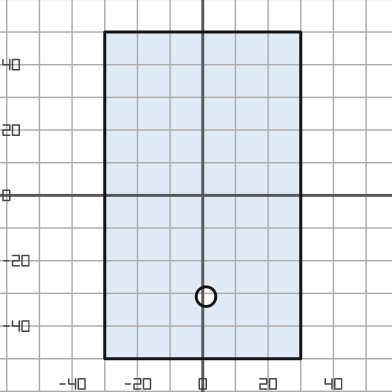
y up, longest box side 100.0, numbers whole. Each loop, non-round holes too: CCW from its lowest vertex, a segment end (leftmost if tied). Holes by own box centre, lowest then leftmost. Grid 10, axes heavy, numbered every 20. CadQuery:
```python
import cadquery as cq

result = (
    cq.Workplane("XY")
    .moveTo(-30.0, -50.0)
    .lineTo(30.0, -50.0)
    .lineTo(30.0, 50.0)
    .lineTo(-30.0, 50.0)
    .close()
    .moveTo(1.0, -31.0)
    .circle(3.0)
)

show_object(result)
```